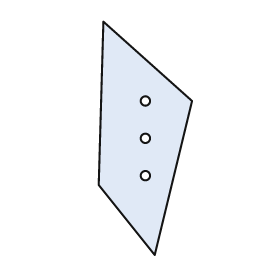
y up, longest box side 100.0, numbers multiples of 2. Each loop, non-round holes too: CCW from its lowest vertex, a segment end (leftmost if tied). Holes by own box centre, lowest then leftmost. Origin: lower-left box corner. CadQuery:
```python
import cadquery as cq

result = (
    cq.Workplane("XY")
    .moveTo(24.0, 0.0)
    .lineTo(40.0, 66.0)
    .lineTo(2.0, 100.0)
    .lineTo(0.0, 30.0)
    .close()
    .moveTo(20.0, 34.0)
    .circle(2.0)
    .moveTo(20.0, 50.0)
    .circle(2.0)
    .moveTo(20.0, 66.0)
    .circle(2.0)
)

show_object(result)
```